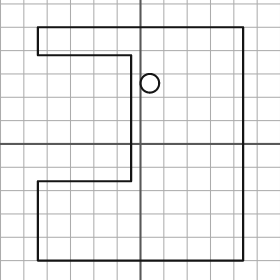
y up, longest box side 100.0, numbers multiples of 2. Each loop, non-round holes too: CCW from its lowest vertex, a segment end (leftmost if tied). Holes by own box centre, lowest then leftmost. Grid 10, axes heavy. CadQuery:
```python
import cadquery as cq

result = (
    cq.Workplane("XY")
    .moveTo(-44.0, -50.0)
    .lineTo(44.0, -50.0)
    .lineTo(44.0, 50.0)
    .lineTo(-44.0, 50.0)
    .lineTo(-44.0, 38.0)
    .lineTo(-4.0, 38.0)
    .lineTo(-4.0, -16.0)
    .lineTo(-44.0, -16.0)
    .close()
    .moveTo(4.0, 26.0)
    .circle(4.0)
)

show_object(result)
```